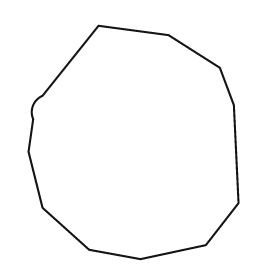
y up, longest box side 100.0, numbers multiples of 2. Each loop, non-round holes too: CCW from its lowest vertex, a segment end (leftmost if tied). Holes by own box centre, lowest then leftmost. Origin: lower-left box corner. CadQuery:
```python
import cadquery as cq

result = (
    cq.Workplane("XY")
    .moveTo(48.0, 0.0)
    .lineTo(76.0, 6.0)
    .lineTo(90.0, 24.0)
    .lineTo(88.0, 66.0)
    .lineTo(82.0, 82.0)
    .lineTo(60.0, 96.0)
    .lineTo(30.0, 100.0)
    .lineTo(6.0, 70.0)
    .threePointArc((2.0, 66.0), (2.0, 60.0))
    .lineTo(0.0, 46.0)
    .lineTo(6.0, 22.0)
    .lineTo(26.0, 4.0)
    .close()
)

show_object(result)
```